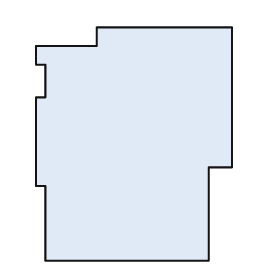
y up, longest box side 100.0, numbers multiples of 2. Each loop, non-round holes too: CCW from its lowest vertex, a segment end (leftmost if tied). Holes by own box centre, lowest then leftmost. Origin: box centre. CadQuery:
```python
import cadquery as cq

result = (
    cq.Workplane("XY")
    .moveTo(-38.0, -50.0)
    .lineTo(32.0, -50.0)
    .lineTo(32.0, -10.0)
    .lineTo(42.0, -10.0)
    .lineTo(42.0, 50.0)
    .lineTo(-16.0, 50.0)
    .lineTo(-16.0, 42.0)
    .lineTo(-42.0, 42.0)
    .lineTo(-42.0, 34.0)
    .lineTo(-38.0, 34.0)
    .lineTo(-38.0, 20.0)
    .lineTo(-42.0, 20.0)
    .lineTo(-42.0, -18.0)
    .lineTo(-38.0, -18.0)
    .close()
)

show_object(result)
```